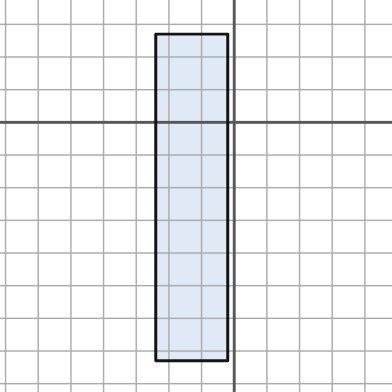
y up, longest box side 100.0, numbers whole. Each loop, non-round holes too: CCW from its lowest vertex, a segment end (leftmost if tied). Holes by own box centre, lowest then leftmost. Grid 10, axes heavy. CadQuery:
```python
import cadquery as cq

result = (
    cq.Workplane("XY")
    .moveTo(-24.0, -73.0)
    .lineTo(-2.0, -73.0)
    .lineTo(-2.0, 27.0)
    .lineTo(-24.0, 27.0)
    .close()
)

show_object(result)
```